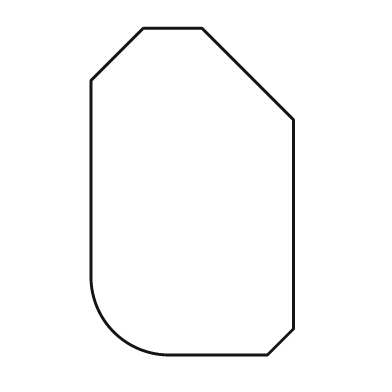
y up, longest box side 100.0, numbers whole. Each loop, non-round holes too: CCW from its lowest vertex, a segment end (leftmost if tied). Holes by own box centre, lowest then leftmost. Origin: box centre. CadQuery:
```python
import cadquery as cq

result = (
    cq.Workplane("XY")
    .moveTo(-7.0, -50.0)
    .lineTo(23.0, -50.0)
    .lineTo(31.0, -42.0)
    .lineTo(31.0, 22.0)
    .lineTo(3.0, 50.0)
    .lineTo(-15.0, 50.0)
    .lineTo(-31.0, 34.0)
    .lineTo(-31.0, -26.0)
    .threePointArc((-24.0, -43.0), (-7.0, -50.0))
    .close()
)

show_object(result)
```